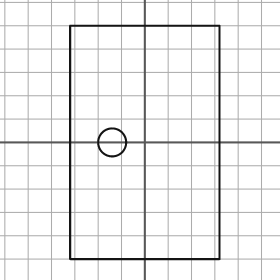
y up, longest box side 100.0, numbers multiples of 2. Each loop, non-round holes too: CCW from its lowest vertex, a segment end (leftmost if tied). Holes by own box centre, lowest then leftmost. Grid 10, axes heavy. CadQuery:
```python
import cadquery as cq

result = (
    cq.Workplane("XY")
    .moveTo(-32.0, -50.0)
    .lineTo(32.0, -50.0)
    .lineTo(32.0, 50.0)
    .lineTo(-32.0, 50.0)
    .close()
    .moveTo(-14.0, 0.0)
    .circle(6.0)
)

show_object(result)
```